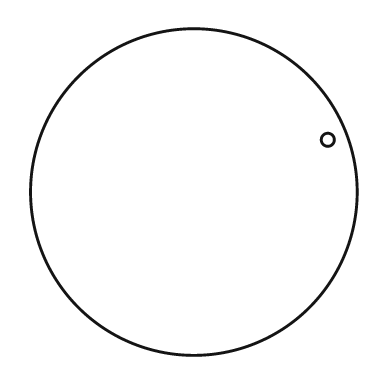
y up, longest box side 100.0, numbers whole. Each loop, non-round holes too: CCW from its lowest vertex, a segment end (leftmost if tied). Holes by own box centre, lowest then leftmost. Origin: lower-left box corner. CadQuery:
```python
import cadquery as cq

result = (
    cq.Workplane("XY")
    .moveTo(50.0, 50.0)
    .circle(50.0)
    .moveTo(91.0, 66.0)
    .circle(2.0)
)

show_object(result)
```